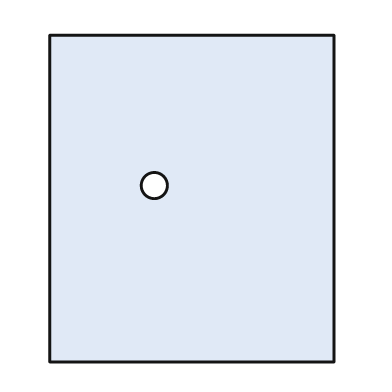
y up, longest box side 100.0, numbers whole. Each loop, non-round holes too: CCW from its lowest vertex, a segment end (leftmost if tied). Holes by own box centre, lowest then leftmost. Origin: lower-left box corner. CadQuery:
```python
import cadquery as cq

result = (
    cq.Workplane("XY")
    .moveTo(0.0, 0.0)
    .lineTo(87.0, 0.0)
    .lineTo(87.0, 100.0)
    .lineTo(0.0, 100.0)
    .close()
    .moveTo(32.0, 54.0)
    .circle(4.0)
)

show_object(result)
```